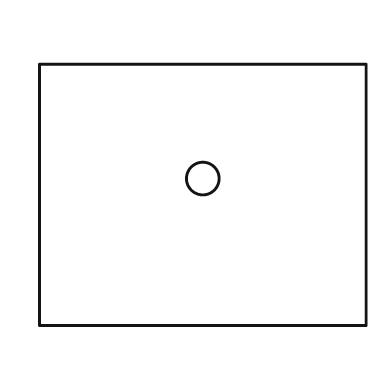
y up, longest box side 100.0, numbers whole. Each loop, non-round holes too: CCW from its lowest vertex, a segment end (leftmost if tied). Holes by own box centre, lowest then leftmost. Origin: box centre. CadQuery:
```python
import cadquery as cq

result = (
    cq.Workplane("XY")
    .moveTo(-50.0, -40.0)
    .lineTo(50.0, -40.0)
    .lineTo(50.0, 40.0)
    .lineTo(-50.0, 40.0)
    .close()
    .moveTo(0.0, 5.0)
    .circle(5.0)
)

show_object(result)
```